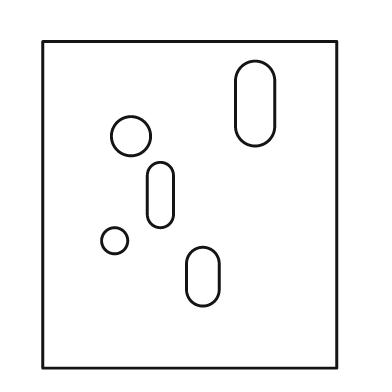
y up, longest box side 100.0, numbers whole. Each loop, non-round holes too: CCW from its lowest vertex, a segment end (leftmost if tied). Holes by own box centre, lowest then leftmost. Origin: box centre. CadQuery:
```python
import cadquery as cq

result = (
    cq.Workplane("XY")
    .moveTo(-45.0, -50.0)
    .lineTo(45.0, -50.0)
    .lineTo(45.0, 50.0)
    .lineTo(-45.0, 50.0)
    .close()
    .moveTo(-1.0, -26.0)
    .threePointArc((4.0, -31.0), (9.0, -26.0))
    .lineTo(9.0, -18.0)
    .threePointArc((4.0, -13.0), (-1.0, -18.0))
    .close()
    .moveTo(-23.0, -11.0)
    .circle(4.0)
    .moveTo(-13.0, -3.0)
    .threePointArc((-9.0, -7.0), (-5.0, -3.0))
    .lineTo(-5.0, 9.0)
    .threePointArc((-9.0, 13.0), (-13.0, 9.0))
    .close()
    .moveTo(-18.0, 21.0)
    .circle(6.0)
    .moveTo(14.0, 24.0)
    .threePointArc((20.0, 18.0), (26.0, 24.0))
    .lineTo(26.0, 38.0)
    .threePointArc((20.0, 44.0), (14.0, 38.0))
    .close()
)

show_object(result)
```